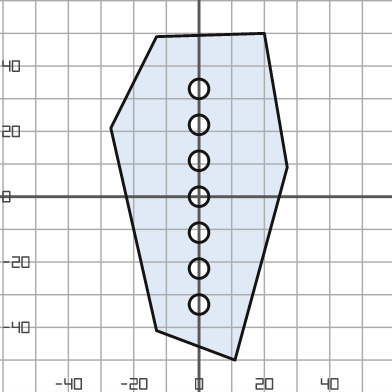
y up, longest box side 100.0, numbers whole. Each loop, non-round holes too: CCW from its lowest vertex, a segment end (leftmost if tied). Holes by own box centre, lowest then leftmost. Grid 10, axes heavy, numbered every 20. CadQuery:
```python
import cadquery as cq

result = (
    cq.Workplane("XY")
    .moveTo(11.0, -50.0)
    .lineTo(27.0, 9.0)
    .lineTo(20.0, 50.0)
    .lineTo(-13.0, 49.0)
    .lineTo(-27.0, 21.0)
    .lineTo(-13.0, -41.0)
    .close()
    .moveTo(0.0, -33.0)
    .circle(3.0)
    .moveTo(0.0, -22.0)
    .circle(3.0)
    .moveTo(0.0, -11.0)
    .circle(3.0)
    .moveTo(0.0, 0.0)
    .circle(3.0)
    .moveTo(0.0, 11.0)
    .circle(3.0)
    .moveTo(0.0, 22.0)
    .circle(3.0)
    .moveTo(0.0, 33.0)
    .circle(3.0)
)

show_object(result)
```